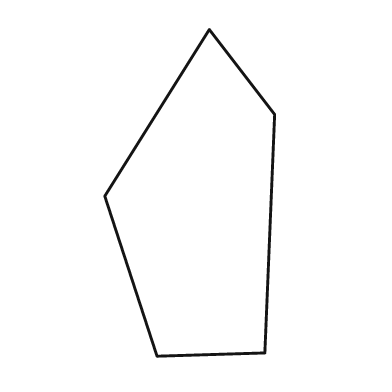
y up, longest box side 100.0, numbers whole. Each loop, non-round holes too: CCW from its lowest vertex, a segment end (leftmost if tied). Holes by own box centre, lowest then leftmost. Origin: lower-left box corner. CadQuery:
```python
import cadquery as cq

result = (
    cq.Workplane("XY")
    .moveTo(16.0, 0.0)
    .lineTo(49.0, 1.0)
    .lineTo(52.0, 74.0)
    .lineTo(32.0, 100.0)
    .lineTo(0.0, 49.0)
    .close()
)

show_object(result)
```